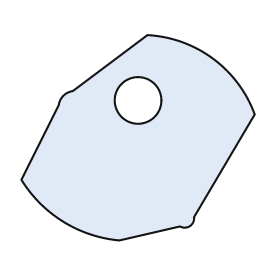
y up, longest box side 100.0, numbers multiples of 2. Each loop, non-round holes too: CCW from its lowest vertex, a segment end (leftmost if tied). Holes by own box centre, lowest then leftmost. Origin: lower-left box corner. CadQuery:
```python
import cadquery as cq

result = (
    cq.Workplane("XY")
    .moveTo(42.0, 0.0)
    .lineTo(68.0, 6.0)
    .threePointArc((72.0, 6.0), (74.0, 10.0))
    .lineTo(100.0, 54.0)
    .threePointArc((82.0, 78.0), (54.0, 88.0))
    .lineTo(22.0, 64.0)
    .threePointArc((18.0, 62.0), (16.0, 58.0))
    .lineTo(0.0, 26.0)
    .threePointArc((18.0, 8.0), (42.0, 0.0))
    .close()
    .moveTo(50.0, 60.0)
    .circle(10.0)
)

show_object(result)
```